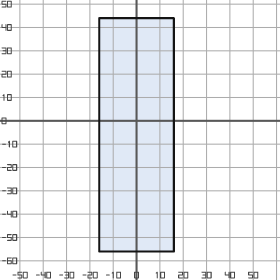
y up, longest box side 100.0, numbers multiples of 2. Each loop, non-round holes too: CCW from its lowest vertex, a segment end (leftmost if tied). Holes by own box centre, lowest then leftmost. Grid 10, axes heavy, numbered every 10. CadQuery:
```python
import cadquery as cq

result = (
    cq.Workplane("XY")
    .moveTo(-16.0, -56.0)
    .lineTo(16.0, -56.0)
    .lineTo(16.0, 44.0)
    .lineTo(-16.0, 44.0)
    .close()
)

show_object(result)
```